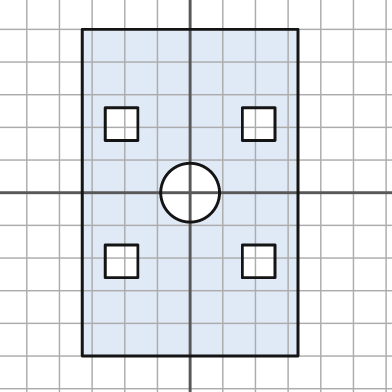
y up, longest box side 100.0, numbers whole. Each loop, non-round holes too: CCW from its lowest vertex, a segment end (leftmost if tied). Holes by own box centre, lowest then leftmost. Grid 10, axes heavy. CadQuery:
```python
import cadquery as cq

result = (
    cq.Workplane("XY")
    .moveTo(-33.0, -50.0)
    .lineTo(33.0, -50.0)
    .lineTo(33.0, 50.0)
    .lineTo(-33.0, 50.0)
    .close()
    .moveTo(-26.0, -26.0)
    .lineTo(-16.0, -26.0)
    .lineTo(-16.0, -16.0)
    .lineTo(-26.0, -16.0)
    .close()
    .moveTo(16.0, -26.0)
    .lineTo(26.0, -26.0)
    .lineTo(26.0, -16.0)
    .lineTo(16.0, -16.0)
    .close()
    .moveTo(0.0, 0.0)
    .circle(9.0)
    .moveTo(-26.0, 16.0)
    .lineTo(-16.0, 16.0)
    .lineTo(-16.0, 26.0)
    .lineTo(-26.0, 26.0)
    .close()
    .moveTo(16.0, 16.0)
    .lineTo(26.0, 16.0)
    .lineTo(26.0, 26.0)
    .lineTo(16.0, 26.0)
    .close()
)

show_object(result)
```